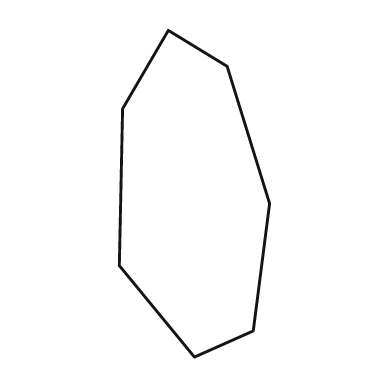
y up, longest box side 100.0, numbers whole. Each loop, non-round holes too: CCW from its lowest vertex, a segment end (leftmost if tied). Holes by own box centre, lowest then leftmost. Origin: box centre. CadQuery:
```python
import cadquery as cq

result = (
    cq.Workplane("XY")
    .moveTo(0.0, -50.0)
    .lineTo(18.0, -42.0)
    .lineTo(23.0, -3.0)
    .lineTo(10.0, 39.0)
    .lineTo(-8.0, 50.0)
    .lineTo(-22.0, 26.0)
    .lineTo(-23.0, -22.0)
    .close()
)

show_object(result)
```